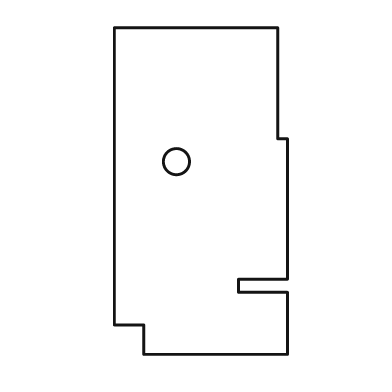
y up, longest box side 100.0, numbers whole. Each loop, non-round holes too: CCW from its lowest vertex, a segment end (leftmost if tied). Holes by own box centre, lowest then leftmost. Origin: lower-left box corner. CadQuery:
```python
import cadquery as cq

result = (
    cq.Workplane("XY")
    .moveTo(9.0, 0.0)
    .lineTo(53.0, 0.0)
    .lineTo(53.0, 19.0)
    .lineTo(38.0, 19.0)
    .lineTo(38.0, 23.0)
    .lineTo(53.0, 23.0)
    .lineTo(53.0, 66.0)
    .lineTo(50.0, 66.0)
    .lineTo(50.0, 100.0)
    .lineTo(0.0, 100.0)
    .lineTo(0.0, 9.0)
    .lineTo(9.0, 9.0)
    .close()
    .moveTo(19.0, 59.0)
    .circle(4.0)
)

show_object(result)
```